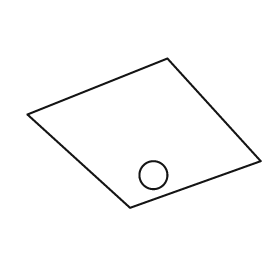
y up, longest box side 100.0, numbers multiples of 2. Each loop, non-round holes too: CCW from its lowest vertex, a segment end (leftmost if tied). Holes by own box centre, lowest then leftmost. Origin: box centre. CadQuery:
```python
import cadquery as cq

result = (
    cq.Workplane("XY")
    .moveTo(-6.0, -32.0)
    .lineTo(50.0, -12.0)
    .lineTo(10.0, 32.0)
    .lineTo(-50.0, 8.0)
    .close()
    .moveTo(4.0, -18.0)
    .circle(6.0)
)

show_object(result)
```